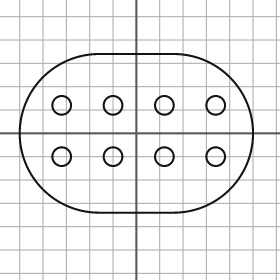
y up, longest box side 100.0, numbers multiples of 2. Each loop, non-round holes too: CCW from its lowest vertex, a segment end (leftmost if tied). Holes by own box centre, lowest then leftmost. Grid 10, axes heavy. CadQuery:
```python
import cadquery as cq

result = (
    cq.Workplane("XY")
    .moveTo(-16.0, -34.0)
    .lineTo(16.0, -34.0)
    .threePointArc((50.0, 0.0), (16.0, 34.0))
    .lineTo(-16.0, 34.0)
    .threePointArc((-50.0, 0.0), (-16.0, -34.0))
    .close()
    .moveTo(-32.0, -10.0)
    .circle(4.0)
    .moveTo(-10.0, -10.0)
    .circle(4.0)
    .moveTo(12.0, -10.0)
    .circle(4.0)
    .moveTo(34.0, -10.0)
    .circle(4.0)
    .moveTo(-32.0, 12.0)
    .circle(4.0)
    .moveTo(-10.0, 12.0)
    .circle(4.0)
    .moveTo(12.0, 12.0)
    .circle(4.0)
    .moveTo(34.0, 12.0)
    .circle(4.0)
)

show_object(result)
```